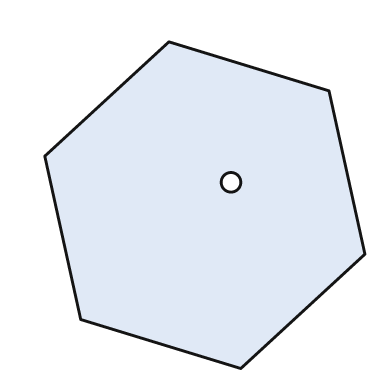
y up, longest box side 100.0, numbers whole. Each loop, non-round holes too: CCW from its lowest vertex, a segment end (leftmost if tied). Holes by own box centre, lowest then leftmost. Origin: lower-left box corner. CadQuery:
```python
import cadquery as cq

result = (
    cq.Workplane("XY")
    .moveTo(60.0, 0.0)
    .lineTo(98.0, 35.0)
    .lineTo(87.0, 85.0)
    .lineTo(38.0, 100.0)
    .lineTo(0.0, 65.0)
    .lineTo(11.0, 15.0)
    .close()
    .moveTo(57.0, 57.0)
    .circle(3.0)
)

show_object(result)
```